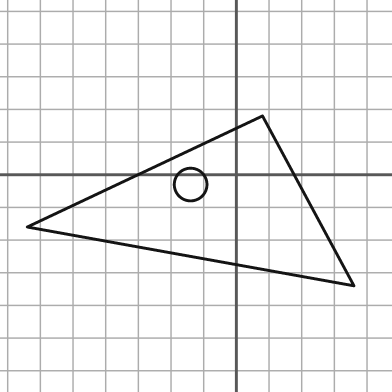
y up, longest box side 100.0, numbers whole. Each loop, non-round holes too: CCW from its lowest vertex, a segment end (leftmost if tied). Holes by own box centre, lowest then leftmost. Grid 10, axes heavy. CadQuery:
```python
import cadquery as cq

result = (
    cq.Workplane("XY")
    .moveTo(36.0, -34.0)
    .lineTo(8.0, 18.0)
    .lineTo(-64.0, -16.0)
    .close()
    .moveTo(-14.0, -3.0)
    .circle(5.0)
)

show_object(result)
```